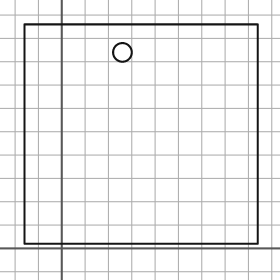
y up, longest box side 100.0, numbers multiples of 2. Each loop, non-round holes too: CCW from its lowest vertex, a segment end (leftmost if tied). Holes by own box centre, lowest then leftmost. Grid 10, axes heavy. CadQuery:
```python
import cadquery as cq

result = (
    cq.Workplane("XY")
    .moveTo(-16.0, 2.0)
    .lineTo(84.0, 2.0)
    .lineTo(84.0, 96.0)
    .lineTo(-16.0, 96.0)
    .close()
    .moveTo(26.0, 84.0)
    .circle(4.0)
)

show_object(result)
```